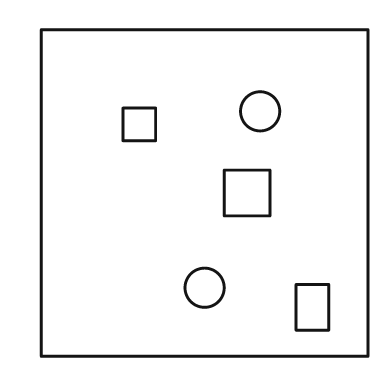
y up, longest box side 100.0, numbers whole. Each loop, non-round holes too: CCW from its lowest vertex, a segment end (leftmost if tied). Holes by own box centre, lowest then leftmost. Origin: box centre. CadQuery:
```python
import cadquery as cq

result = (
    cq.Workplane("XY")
    .moveTo(-50.0, -50.0)
    .lineTo(50.0, -50.0)
    .lineTo(50.0, 50.0)
    .lineTo(-50.0, 50.0)
    .close()
    .moveTo(28.0, -42.0)
    .lineTo(38.0, -42.0)
    .lineTo(38.0, -28.0)
    .lineTo(28.0, -28.0)
    .close()
    .moveTo(0.0, -29.0)
    .circle(6.0)
    .moveTo(6.0, -7.0)
    .lineTo(20.0, -7.0)
    .lineTo(20.0, 7.0)
    .lineTo(6.0, 7.0)
    .close()
    .moveTo(-25.0, 16.0)
    .lineTo(-15.0, 16.0)
    .lineTo(-15.0, 26.0)
    .lineTo(-25.0, 26.0)
    .close()
    .moveTo(17.0, 25.0)
    .circle(6.0)
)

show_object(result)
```